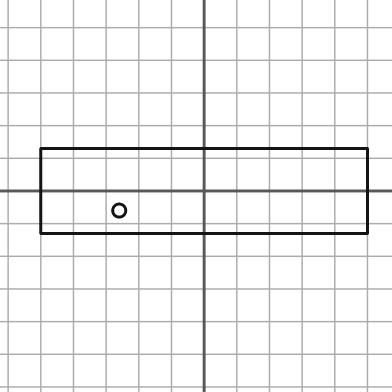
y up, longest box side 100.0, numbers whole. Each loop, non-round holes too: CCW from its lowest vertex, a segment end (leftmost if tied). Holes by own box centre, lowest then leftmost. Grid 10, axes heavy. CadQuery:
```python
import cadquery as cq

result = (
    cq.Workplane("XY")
    .moveTo(-50.0, -13.0)
    .lineTo(50.0, -13.0)
    .lineTo(50.0, 13.0)
    .lineTo(-50.0, 13.0)
    .close()
    .moveTo(-26.0, -6.0)
    .circle(2.0)
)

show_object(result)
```